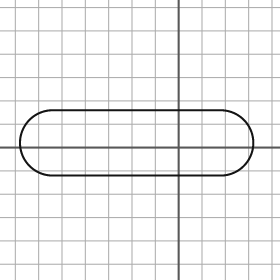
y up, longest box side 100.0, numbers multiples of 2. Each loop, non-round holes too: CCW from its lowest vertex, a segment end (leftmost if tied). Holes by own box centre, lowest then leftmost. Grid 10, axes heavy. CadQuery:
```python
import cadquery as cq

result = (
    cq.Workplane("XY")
    .moveTo(-54.0, -12.0)
    .lineTo(18.0, -12.0)
    .threePointArc((32.0, 2.0), (18.0, 16.0))
    .lineTo(-54.0, 16.0)
    .threePointArc((-68.0, 2.0), (-54.0, -12.0))
    .close()
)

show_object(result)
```